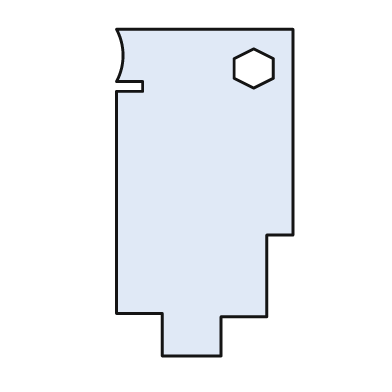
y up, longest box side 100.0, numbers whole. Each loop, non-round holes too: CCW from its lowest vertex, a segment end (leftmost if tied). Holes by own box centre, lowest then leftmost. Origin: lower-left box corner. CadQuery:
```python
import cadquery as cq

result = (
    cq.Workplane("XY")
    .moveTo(14.0, 0.0)
    .lineTo(32.0, 0.0)
    .lineTo(32.0, 12.0)
    .lineTo(46.0, 12.0)
    .lineTo(46.0, 37.0)
    .lineTo(54.0, 37.0)
    .lineTo(54.0, 100.0)
    .lineTo(0.0, 100.0)
    .threePointArc((2.0, 92.0), (0.0, 84.0))
    .lineTo(8.0, 84.0)
    .lineTo(8.0, 81.0)
    .lineTo(0.0, 81.0)
    .lineTo(0.0, 13.0)
    .lineTo(14.0, 13.0)
    .close()
    .moveTo(42.0, 82.0)
    .lineTo(48.0, 85.0)
    .lineTo(48.0, 91.0)
    .lineTo(42.0, 94.0)
    .lineTo(36.0, 91.0)
    .lineTo(36.0, 85.0)
    .close()
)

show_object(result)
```